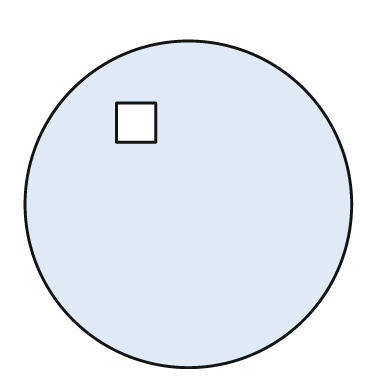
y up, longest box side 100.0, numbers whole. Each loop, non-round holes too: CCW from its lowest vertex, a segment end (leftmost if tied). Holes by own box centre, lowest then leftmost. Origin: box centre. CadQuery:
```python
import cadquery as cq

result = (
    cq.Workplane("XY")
    .moveTo(0.0, 0.0)
    .circle(50.0)
    .moveTo(-22.0, 19.0)
    .lineTo(-10.0, 19.0)
    .lineTo(-10.0, 31.0)
    .lineTo(-22.0, 31.0)
    .close()
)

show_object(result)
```